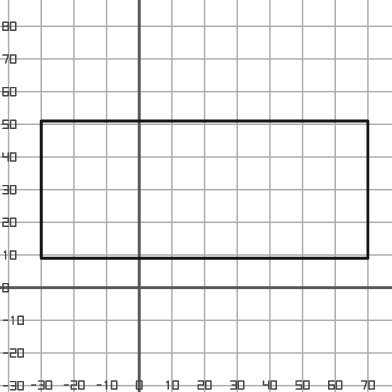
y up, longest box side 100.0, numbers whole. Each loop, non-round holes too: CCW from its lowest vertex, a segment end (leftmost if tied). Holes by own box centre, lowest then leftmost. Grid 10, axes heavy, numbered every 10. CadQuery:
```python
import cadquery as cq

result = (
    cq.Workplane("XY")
    .moveTo(-30.0, 9.0)
    .lineTo(70.0, 9.0)
    .lineTo(70.0, 51.0)
    .lineTo(-30.0, 51.0)
    .close()
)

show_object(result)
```